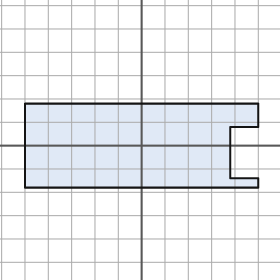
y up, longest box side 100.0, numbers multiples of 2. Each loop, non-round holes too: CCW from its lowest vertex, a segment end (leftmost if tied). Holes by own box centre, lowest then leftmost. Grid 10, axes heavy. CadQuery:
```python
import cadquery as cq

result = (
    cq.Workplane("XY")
    .moveTo(-50.0, -18.0)
    .lineTo(50.0, -18.0)
    .lineTo(50.0, -14.0)
    .lineTo(38.0, -14.0)
    .lineTo(38.0, 8.0)
    .lineTo(50.0, 8.0)
    .lineTo(50.0, 18.0)
    .lineTo(-50.0, 18.0)
    .close()
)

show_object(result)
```